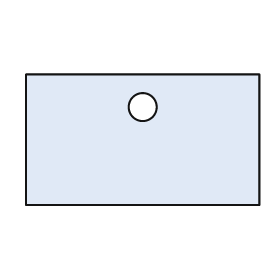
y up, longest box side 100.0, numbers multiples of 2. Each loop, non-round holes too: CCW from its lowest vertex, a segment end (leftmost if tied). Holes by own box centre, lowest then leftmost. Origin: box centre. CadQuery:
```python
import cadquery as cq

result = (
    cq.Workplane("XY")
    .moveTo(-50.0, -28.0)
    .lineTo(50.0, -28.0)
    .lineTo(50.0, 28.0)
    .lineTo(-50.0, 28.0)
    .close()
    .moveTo(0.0, 14.0)
    .circle(6.0)
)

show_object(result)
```